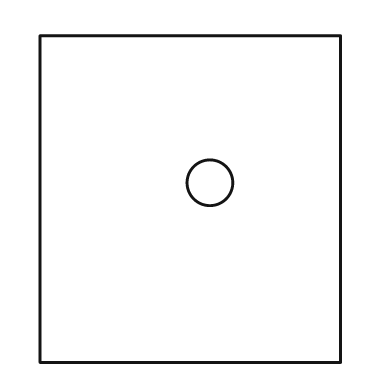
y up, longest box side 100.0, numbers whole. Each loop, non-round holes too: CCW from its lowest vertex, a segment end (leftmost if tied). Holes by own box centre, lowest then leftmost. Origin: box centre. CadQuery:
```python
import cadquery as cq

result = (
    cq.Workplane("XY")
    .moveTo(-46.0, -50.0)
    .lineTo(46.0, -50.0)
    .lineTo(46.0, 50.0)
    .lineTo(-46.0, 50.0)
    .close()
    .moveTo(6.0, 5.0)
    .circle(7.0)
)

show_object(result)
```